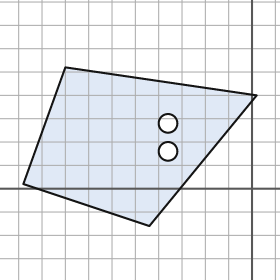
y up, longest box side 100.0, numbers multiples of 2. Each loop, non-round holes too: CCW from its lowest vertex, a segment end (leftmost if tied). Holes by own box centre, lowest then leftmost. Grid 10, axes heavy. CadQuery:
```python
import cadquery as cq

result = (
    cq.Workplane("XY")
    .moveTo(-44.0, -16.0)
    .lineTo(2.0, 40.0)
    .lineTo(-80.0, 52.0)
    .lineTo(-98.0, 2.0)
    .close()
    .moveTo(-36.0, 16.0)
    .circle(4.0)
    .moveTo(-36.0, 28.0)
    .circle(4.0)
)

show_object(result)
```